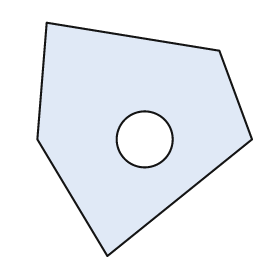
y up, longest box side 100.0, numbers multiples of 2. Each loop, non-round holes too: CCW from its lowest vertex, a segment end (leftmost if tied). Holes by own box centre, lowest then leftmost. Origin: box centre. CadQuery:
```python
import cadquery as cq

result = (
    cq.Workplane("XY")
    .moveTo(-16.0, -50.0)
    .lineTo(46.0, 0.0)
    .lineTo(32.0, 38.0)
    .lineTo(-42.0, 50.0)
    .lineTo(-46.0, 0.0)
    .close()
    .moveTo(0.0, 0.0)
    .circle(12.0)
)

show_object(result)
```